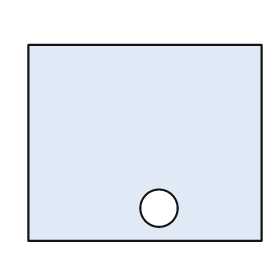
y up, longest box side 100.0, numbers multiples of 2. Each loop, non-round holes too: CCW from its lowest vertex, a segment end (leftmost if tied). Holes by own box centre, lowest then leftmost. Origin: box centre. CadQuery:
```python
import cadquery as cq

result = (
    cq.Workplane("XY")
    .moveTo(-50.0, -42.0)
    .lineTo(50.0, -42.0)
    .lineTo(50.0, 42.0)
    .lineTo(-50.0, 42.0)
    .close()
    .moveTo(6.0, -28.0)
    .circle(8.0)
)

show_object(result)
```